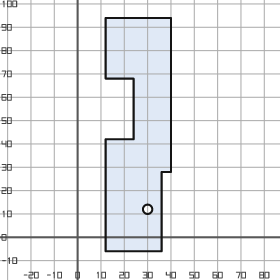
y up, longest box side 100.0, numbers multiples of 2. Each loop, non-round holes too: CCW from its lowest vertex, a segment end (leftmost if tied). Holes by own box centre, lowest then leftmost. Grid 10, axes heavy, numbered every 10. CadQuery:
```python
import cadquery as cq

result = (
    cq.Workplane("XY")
    .moveTo(12.0, -6.0)
    .lineTo(36.0, -6.0)
    .lineTo(36.0, 28.0)
    .lineTo(40.0, 28.0)
    .lineTo(40.0, 94.0)
    .lineTo(12.0, 94.0)
    .lineTo(12.0, 68.0)
    .lineTo(24.0, 68.0)
    .lineTo(24.0, 42.0)
    .lineTo(12.0, 42.0)
    .close()
    .moveTo(30.0, 12.0)
    .circle(2.0)
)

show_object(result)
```